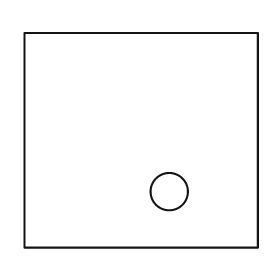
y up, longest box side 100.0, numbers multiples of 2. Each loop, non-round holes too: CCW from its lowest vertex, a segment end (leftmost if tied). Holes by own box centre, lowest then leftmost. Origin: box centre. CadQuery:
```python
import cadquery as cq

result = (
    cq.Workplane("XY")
    .moveTo(-50.0, -46.0)
    .lineTo(50.0, -46.0)
    .lineTo(50.0, 46.0)
    .lineTo(-50.0, 46.0)
    .close()
    .moveTo(12.0, -22.0)
    .circle(8.0)
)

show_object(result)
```